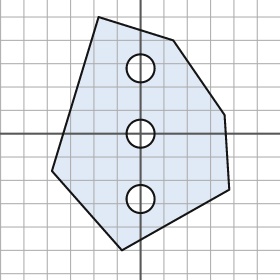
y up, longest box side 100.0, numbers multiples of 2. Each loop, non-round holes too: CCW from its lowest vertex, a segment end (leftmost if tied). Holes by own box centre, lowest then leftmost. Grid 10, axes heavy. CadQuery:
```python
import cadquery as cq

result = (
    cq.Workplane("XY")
    .moveTo(-8.0, -50.0)
    .lineTo(38.0, -24.0)
    .lineTo(36.0, 8.0)
    .lineTo(14.0, 40.0)
    .lineTo(-18.0, 50.0)
    .lineTo(-38.0, -16.0)
    .close()
    .moveTo(0.0, -28.0)
    .circle(6.0)
    .moveTo(0.0, 0.0)
    .circle(6.0)
    .moveTo(0.0, 28.0)
    .circle(6.0)
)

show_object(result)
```